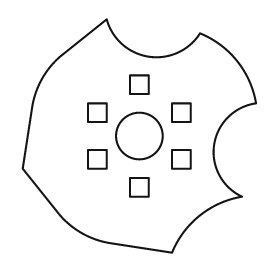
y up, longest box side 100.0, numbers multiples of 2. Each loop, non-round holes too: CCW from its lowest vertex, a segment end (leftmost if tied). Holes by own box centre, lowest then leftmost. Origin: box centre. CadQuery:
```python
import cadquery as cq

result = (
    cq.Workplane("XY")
    .moveTo(14.0, -50.0)
    .threePointArc((26.0, -34.0), (44.0, -26.0))
    .threePointArc((32.0, -4.0), (50.0, 14.0))
    .threePointArc((42.0, 32.0), (26.0, 44.0))
    .threePointArc((4.0, 34.0), (-14.0, 50.0))
    .lineTo(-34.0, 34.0)
    .threePointArc((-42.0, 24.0), (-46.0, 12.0))
    .lineTo(-50.0, -14.0)
    .lineTo(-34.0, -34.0)
    .threePointArc((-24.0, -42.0), (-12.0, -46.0))
    .close()
    .moveTo(-4.0, -26.0)
    .lineTo(4.0, -26.0)
    .lineTo(4.0, -18.0)
    .lineTo(-4.0, -18.0)
    .close()
    .moveTo(-22.0, -14.0)
    .lineTo(-14.0, -14.0)
    .lineTo(-14.0, -6.0)
    .lineTo(-22.0, -6.0)
    .close()
    .moveTo(14.0, -14.0)
    .lineTo(22.0, -14.0)
    .lineTo(22.0, -6.0)
    .lineTo(14.0, -6.0)
    .close()
    .moveTo(0.0, 0.0)
    .circle(10.0)
    .moveTo(-22.0, 6.0)
    .lineTo(-14.0, 6.0)
    .lineTo(-14.0, 14.0)
    .lineTo(-22.0, 14.0)
    .close()
    .moveTo(14.0, 6.0)
    .lineTo(22.0, 6.0)
    .lineTo(22.0, 14.0)
    .lineTo(14.0, 14.0)
    .close()
    .moveTo(-4.0, 18.0)
    .lineTo(4.0, 18.0)
    .lineTo(4.0, 26.0)
    .lineTo(-4.0, 26.0)
    .close()
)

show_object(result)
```